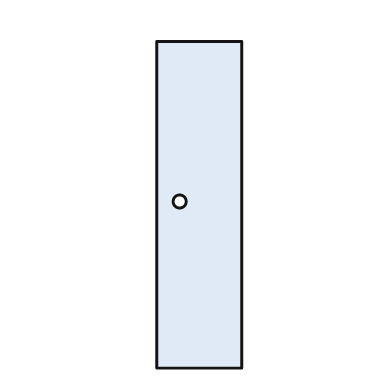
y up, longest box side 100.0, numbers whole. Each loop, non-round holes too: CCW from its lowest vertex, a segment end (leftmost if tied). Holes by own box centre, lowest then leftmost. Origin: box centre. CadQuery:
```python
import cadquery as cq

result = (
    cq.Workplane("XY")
    .moveTo(-13.0, -50.0)
    .lineTo(13.0, -50.0)
    .lineTo(13.0, 50.0)
    .lineTo(-13.0, 50.0)
    .close()
    .moveTo(-6.0, 1.0)
    .circle(2.0)
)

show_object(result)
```